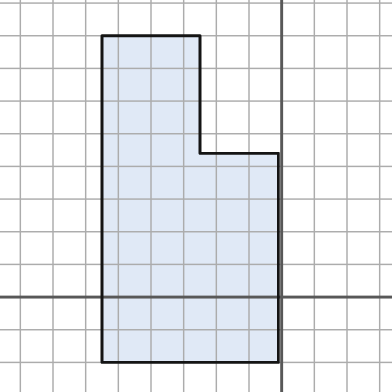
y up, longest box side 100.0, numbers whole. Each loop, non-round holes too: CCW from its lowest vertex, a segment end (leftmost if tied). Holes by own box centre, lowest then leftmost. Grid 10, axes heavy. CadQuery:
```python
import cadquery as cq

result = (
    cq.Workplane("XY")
    .moveTo(-55.0, -20.0)
    .lineTo(-1.0, -20.0)
    .lineTo(-1.0, 44.0)
    .lineTo(-25.0, 44.0)
    .lineTo(-25.0, 80.0)
    .lineTo(-55.0, 80.0)
    .close()
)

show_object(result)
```